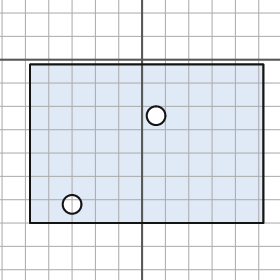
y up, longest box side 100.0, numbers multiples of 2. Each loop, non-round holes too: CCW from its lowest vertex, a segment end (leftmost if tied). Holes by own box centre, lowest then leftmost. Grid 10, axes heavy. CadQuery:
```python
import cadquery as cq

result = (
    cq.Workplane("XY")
    .moveTo(-48.0, -70.0)
    .lineTo(52.0, -70.0)
    .lineTo(52.0, -2.0)
    .lineTo(-48.0, -2.0)
    .close()
    .moveTo(-30.0, -62.0)
    .circle(4.0)
    .moveTo(6.0, -24.0)
    .circle(4.0)
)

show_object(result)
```